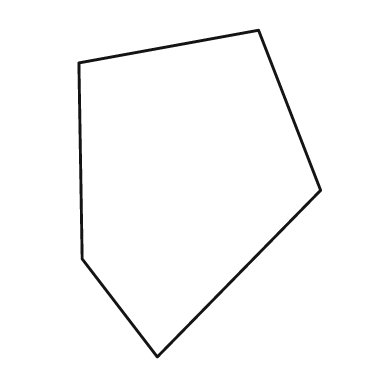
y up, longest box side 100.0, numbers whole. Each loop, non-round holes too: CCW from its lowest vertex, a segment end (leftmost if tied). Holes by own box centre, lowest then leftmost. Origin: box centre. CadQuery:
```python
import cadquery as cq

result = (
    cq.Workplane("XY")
    .moveTo(-13.0, -50.0)
    .lineTo(37.0, 1.0)
    .lineTo(18.0, 50.0)
    .lineTo(-37.0, 40.0)
    .lineTo(-36.0, -20.0)
    .close()
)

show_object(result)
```